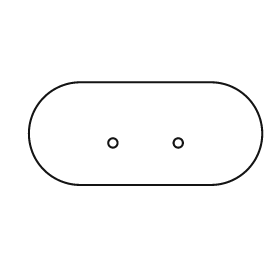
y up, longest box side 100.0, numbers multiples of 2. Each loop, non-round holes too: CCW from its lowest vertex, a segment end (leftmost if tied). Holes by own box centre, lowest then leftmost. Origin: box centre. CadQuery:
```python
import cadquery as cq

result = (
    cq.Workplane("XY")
    .moveTo(-28.0, -22.0)
    .lineTo(28.0, -22.0)
    .threePointArc((50.0, 0.0), (28.0, 22.0))
    .lineTo(-28.0, 22.0)
    .threePointArc((-50.0, 0.0), (-28.0, -22.0))
    .close()
    .moveTo(-14.0, -4.0)
    .circle(2.0)
    .moveTo(14.0, -4.0)
    .circle(2.0)
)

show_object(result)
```